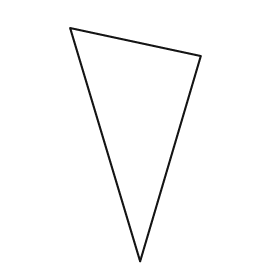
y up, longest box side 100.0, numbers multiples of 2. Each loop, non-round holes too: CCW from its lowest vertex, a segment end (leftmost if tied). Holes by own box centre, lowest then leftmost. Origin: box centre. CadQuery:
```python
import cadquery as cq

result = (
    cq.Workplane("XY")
    .moveTo(2.0, -50.0)
    .lineTo(28.0, 38.0)
    .lineTo(-28.0, 50.0)
    .close()
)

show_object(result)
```